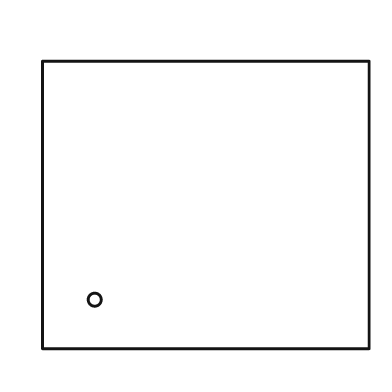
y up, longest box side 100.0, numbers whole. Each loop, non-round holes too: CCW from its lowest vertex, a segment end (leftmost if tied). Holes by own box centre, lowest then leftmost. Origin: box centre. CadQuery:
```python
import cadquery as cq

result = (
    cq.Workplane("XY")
    .moveTo(-50.0, -44.0)
    .lineTo(50.0, -44.0)
    .lineTo(50.0, 44.0)
    .lineTo(-50.0, 44.0)
    .close()
    .moveTo(-34.0, -29.0)
    .circle(2.0)
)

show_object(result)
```